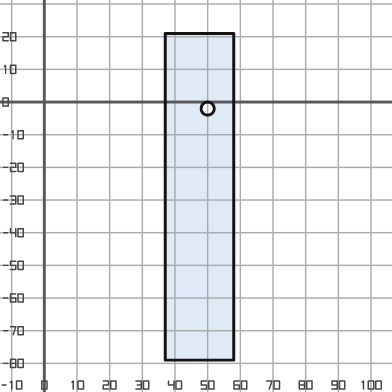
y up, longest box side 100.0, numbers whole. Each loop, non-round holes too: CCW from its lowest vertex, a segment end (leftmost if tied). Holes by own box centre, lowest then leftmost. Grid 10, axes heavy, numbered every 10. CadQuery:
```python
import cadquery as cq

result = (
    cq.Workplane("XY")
    .moveTo(37.0, -79.0)
    .lineTo(58.0, -79.0)
    .lineTo(58.0, 21.0)
    .lineTo(37.0, 21.0)
    .close()
    .moveTo(50.0, -2.0)
    .circle(2.0)
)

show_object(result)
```